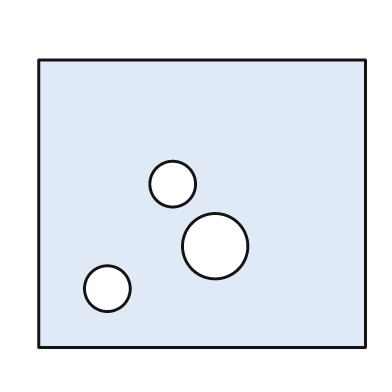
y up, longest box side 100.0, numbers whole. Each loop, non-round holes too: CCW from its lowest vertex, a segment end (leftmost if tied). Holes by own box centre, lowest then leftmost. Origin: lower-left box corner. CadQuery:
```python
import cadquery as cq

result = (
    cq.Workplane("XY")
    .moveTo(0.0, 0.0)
    .lineTo(100.0, 0.0)
    .lineTo(100.0, 88.0)
    .lineTo(0.0, 88.0)
    .close()
    .moveTo(21.0, 18.0)
    .circle(7.0)
    .moveTo(54.0, 31.0)
    .circle(10.0)
    .moveTo(41.0, 50.0)
    .circle(7.0)
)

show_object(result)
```